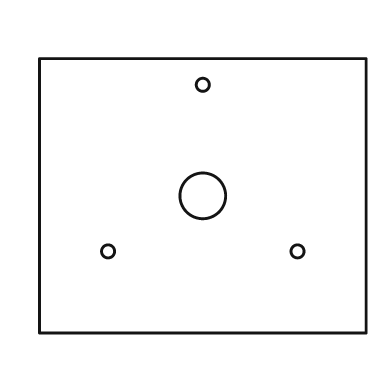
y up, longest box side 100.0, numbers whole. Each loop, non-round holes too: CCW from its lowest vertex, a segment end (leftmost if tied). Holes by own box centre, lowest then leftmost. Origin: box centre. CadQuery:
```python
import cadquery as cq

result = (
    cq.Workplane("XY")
    .moveTo(-50.0, -42.0)
    .lineTo(50.0, -42.0)
    .lineTo(50.0, 42.0)
    .lineTo(-50.0, 42.0)
    .close()
    .moveTo(-29.0, -17.0)
    .circle(2.0)
    .moveTo(29.0, -17.0)
    .circle(2.0)
    .moveTo(0.0, 0.0)
    .circle(7.0)
    .moveTo(0.0, 34.0)
    .circle(2.0)
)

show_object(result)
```